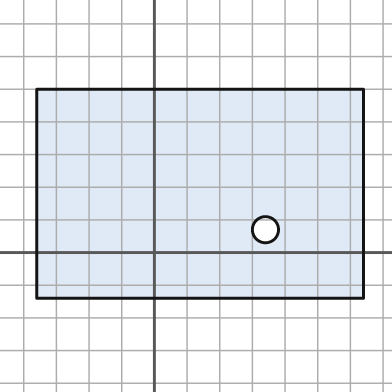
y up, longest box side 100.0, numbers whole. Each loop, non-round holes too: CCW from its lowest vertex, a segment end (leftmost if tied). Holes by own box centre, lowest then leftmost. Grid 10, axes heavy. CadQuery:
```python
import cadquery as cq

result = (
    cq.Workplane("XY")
    .moveTo(-36.0, -14.0)
    .lineTo(64.0, -14.0)
    .lineTo(64.0, 50.0)
    .lineTo(-36.0, 50.0)
    .close()
    .moveTo(34.0, 7.0)
    .circle(4.0)
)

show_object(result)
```